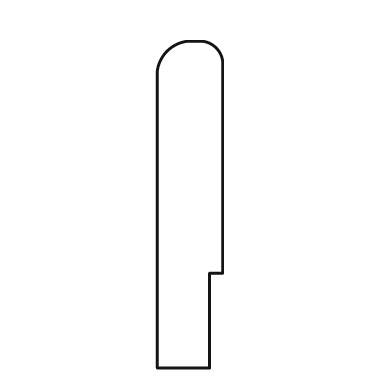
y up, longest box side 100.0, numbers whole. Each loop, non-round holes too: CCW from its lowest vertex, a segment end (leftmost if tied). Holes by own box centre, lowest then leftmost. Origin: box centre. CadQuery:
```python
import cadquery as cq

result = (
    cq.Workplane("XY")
    .moveTo(-10.0, -50.0)
    .lineTo(6.0, -50.0)
    .lineTo(6.0, -21.0)
    .lineTo(10.0, -21.0)
    .lineTo(10.0, 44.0)
    .threePointArc((8.0, 48.0), (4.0, 50.0))
    .lineTo(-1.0, 50.0)
    .threePointArc((-7.0, 47.0), (-10.0, 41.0))
    .close()
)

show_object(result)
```